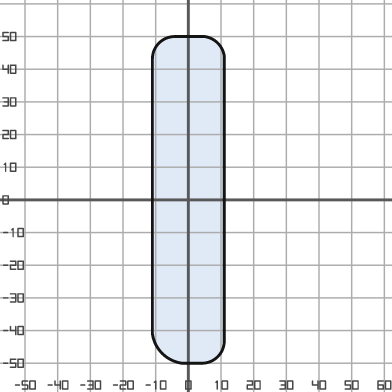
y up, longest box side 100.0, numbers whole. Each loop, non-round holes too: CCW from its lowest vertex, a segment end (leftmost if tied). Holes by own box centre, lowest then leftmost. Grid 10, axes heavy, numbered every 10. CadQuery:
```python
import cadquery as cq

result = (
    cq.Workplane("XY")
    .moveTo(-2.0, -50.0)
    .lineTo(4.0, -50.0)
    .threePointArc((9.0, -48.0), (11.0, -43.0))
    .lineTo(11.0, 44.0)
    .threePointArc((9.0, 48.0), (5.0, 50.0))
    .lineTo(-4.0, 50.0)
    .threePointArc((-9.0, 48.0), (-11.0, 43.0))
    .lineTo(-11.0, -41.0)
    .threePointArc((-8.0, -47.0), (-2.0, -50.0))
    .close()
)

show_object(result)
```